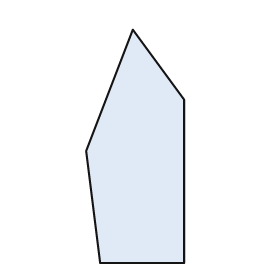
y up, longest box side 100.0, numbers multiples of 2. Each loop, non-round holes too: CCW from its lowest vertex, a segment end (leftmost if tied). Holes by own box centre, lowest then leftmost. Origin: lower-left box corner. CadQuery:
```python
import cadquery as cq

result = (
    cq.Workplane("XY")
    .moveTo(6.0, 0.0)
    .lineTo(42.0, 0.0)
    .lineTo(42.0, 70.0)
    .lineTo(20.0, 100.0)
    .lineTo(0.0, 48.0)
    .close()
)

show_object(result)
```